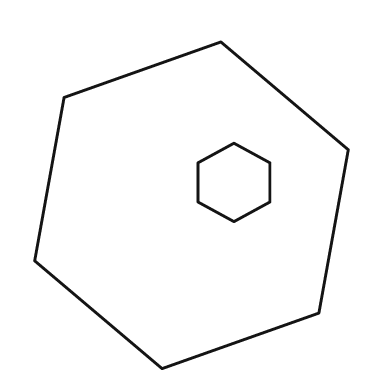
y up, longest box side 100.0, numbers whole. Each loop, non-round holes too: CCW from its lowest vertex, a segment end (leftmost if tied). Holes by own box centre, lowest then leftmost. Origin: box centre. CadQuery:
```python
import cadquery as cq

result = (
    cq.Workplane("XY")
    .moveTo(-9.0, -50.0)
    .lineTo(39.0, -33.0)
    .lineTo(48.0, 17.0)
    .lineTo(9.0, 50.0)
    .lineTo(-39.0, 33.0)
    .lineTo(-48.0, -17.0)
    .close()
    .moveTo(13.0, -5.0)
    .lineTo(24.0, 1.0)
    .lineTo(24.0, 13.0)
    .lineTo(13.0, 19.0)
    .lineTo(2.0, 13.0)
    .lineTo(2.0, 1.0)
    .close()
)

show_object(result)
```